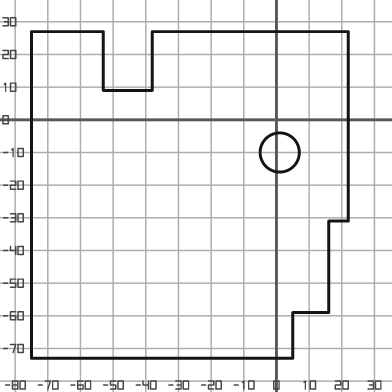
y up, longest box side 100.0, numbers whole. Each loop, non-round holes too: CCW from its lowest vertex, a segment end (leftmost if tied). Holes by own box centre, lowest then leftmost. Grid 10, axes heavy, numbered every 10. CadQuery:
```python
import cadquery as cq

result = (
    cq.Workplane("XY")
    .moveTo(-75.0, -73.0)
    .lineTo(5.0, -73.0)
    .lineTo(5.0, -59.0)
    .lineTo(16.0, -59.0)
    .lineTo(16.0, -31.0)
    .lineTo(22.0, -31.0)
    .lineTo(22.0, 27.0)
    .lineTo(-38.0, 27.0)
    .lineTo(-38.0, 9.0)
    .lineTo(-53.0, 9.0)
    .lineTo(-53.0, 27.0)
    .lineTo(-75.0, 27.0)
    .close()
    .moveTo(1.0, -10.0)
    .circle(6.0)
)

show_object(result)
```